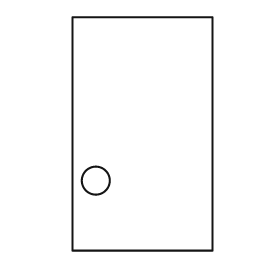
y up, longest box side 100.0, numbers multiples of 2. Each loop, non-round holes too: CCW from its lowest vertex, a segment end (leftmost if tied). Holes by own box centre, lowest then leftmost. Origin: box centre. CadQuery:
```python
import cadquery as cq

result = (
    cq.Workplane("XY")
    .moveTo(-30.0, -50.0)
    .lineTo(30.0, -50.0)
    .lineTo(30.0, 50.0)
    .lineTo(-30.0, 50.0)
    .close()
    .moveTo(-20.0, -20.0)
    .circle(6.0)
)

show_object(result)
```